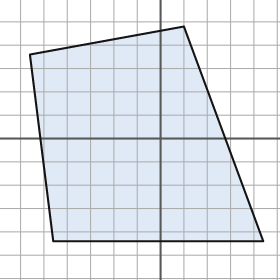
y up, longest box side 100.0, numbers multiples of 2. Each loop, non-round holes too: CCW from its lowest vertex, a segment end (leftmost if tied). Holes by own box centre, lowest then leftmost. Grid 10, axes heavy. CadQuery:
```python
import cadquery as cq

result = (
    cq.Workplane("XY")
    .moveTo(-46.0, -44.0)
    .lineTo(44.0, -44.0)
    .lineTo(10.0, 48.0)
    .lineTo(-56.0, 36.0)
    .close()
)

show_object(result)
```